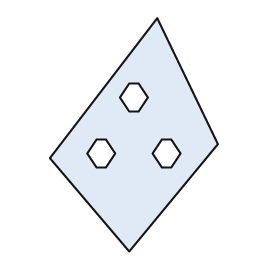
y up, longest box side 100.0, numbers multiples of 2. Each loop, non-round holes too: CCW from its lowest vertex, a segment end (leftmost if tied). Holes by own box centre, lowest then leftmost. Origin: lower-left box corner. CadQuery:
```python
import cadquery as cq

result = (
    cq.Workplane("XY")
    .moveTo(34.0, 0.0)
    .lineTo(72.0, 46.0)
    .lineTo(46.0, 100.0)
    .lineTo(0.0, 40.0)
    .close()
    .moveTo(20.0, 36.0)
    .lineTo(24.0, 36.0)
    .lineTo(28.0, 42.0)
    .lineTo(24.0, 48.0)
    .lineTo(20.0, 48.0)
    .lineTo(16.0, 42.0)
    .close()
    .moveTo(48.0, 36.0)
    .lineTo(52.0, 36.0)
    .lineTo(56.0, 42.0)
    .lineTo(52.0, 48.0)
    .lineTo(48.0, 48.0)
    .lineTo(44.0, 42.0)
    .close()
    .moveTo(34.0, 60.0)
    .lineTo(38.0, 60.0)
    .lineTo(42.0, 66.0)
    .lineTo(38.0, 72.0)
    .lineTo(34.0, 72.0)
    .lineTo(30.0, 66.0)
    .close()
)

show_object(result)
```